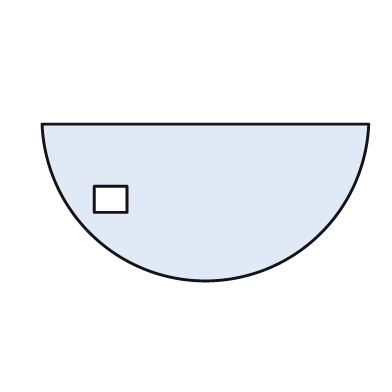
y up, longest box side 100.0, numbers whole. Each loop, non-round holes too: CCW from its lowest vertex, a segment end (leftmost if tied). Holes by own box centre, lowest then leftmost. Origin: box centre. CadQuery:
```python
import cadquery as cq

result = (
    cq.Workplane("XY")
    .moveTo(-50.0, 24.0)
    .threePointArc((0.0, -24.0), (50.0, 24.0))
    .close()
    .moveTo(-34.0, -3.0)
    .lineTo(-24.0, -3.0)
    .lineTo(-24.0, 5.0)
    .lineTo(-34.0, 5.0)
    .close()
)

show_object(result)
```